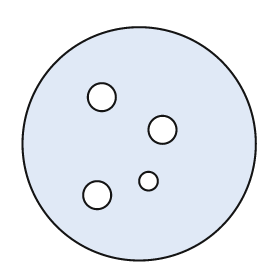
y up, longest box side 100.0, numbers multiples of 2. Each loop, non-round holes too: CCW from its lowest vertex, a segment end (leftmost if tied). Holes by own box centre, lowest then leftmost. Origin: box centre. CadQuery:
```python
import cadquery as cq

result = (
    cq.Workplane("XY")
    .moveTo(0.0, 0.0)
    .circle(50.0)
    .moveTo(-18.0, -22.0)
    .circle(6.0)
    .moveTo(4.0, -16.0)
    .circle(4.0)
    .moveTo(10.0, 6.0)
    .circle(6.0)
    .moveTo(-16.0, 20.0)
    .circle(6.0)
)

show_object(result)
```